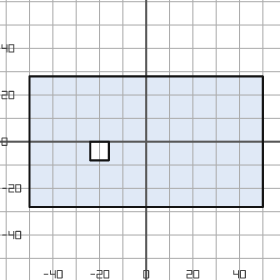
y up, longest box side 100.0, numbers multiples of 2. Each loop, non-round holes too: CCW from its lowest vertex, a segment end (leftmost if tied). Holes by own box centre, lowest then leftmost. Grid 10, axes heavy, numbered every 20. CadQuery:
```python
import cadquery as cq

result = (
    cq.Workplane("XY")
    .moveTo(-50.0, -28.0)
    .lineTo(50.0, -28.0)
    .lineTo(50.0, 28.0)
    .lineTo(-50.0, 28.0)
    .close()
    .moveTo(-24.0, -8.0)
    .lineTo(-16.0, -8.0)
    .lineTo(-16.0, 0.0)
    .lineTo(-24.0, 0.0)
    .close()
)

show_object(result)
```